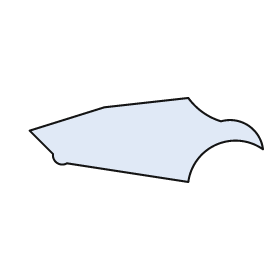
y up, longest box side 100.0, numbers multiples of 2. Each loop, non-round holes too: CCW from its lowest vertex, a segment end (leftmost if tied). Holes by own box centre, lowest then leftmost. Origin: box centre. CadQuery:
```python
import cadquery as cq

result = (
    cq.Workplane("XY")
    .moveTo(18.0, -18.0)
    .threePointArc((30.0, -2.0), (50.0, -4.0))
    .threePointArc((44.0, 6.0), (32.0, 8.0))
    .threePointArc((24.0, 12.0), (18.0, 18.0))
    .lineTo(-18.0, 14.0)
    .lineTo(-50.0, 4.0)
    .lineTo(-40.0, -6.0)
    .threePointArc((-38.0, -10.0), (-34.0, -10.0))
    .close()
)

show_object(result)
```